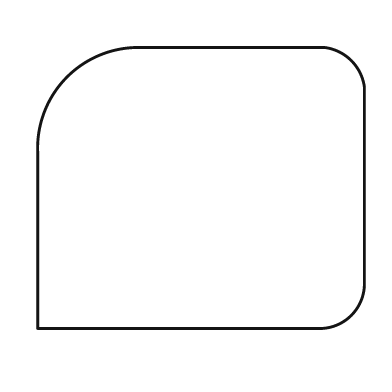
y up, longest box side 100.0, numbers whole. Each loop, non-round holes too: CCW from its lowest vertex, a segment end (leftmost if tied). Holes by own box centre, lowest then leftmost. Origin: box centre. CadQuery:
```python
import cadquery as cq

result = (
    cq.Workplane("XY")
    .moveTo(-50.0, -43.0)
    .lineTo(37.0, -43.0)
    .threePointArc((46.0, -39.0), (50.0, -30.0))
    .lineTo(50.0, 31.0)
    .threePointArc((46.0, 39.0), (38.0, 43.0))
    .lineTo(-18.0, 43.0)
    .threePointArc((-41.0, 34.0), (-50.0, 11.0))
    .close()
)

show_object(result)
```